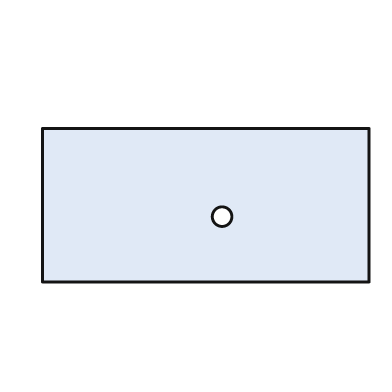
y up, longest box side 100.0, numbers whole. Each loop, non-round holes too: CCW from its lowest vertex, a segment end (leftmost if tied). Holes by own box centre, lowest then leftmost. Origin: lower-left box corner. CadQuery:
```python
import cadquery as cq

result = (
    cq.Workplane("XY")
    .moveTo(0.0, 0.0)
    .lineTo(100.0, 0.0)
    .lineTo(100.0, 47.0)
    .lineTo(0.0, 47.0)
    .close()
    .moveTo(55.0, 20.0)
    .circle(3.0)
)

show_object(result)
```